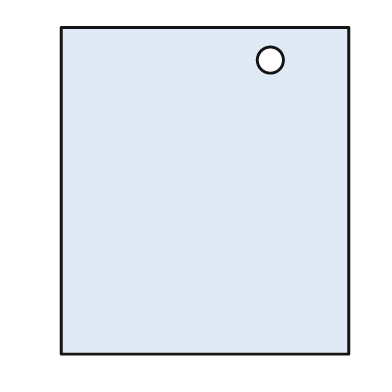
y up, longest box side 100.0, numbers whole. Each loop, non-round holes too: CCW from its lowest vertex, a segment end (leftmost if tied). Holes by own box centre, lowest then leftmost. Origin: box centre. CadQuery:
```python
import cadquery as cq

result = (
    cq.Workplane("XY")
    .moveTo(-44.0, -50.0)
    .lineTo(44.0, -50.0)
    .lineTo(44.0, 50.0)
    .lineTo(-44.0, 50.0)
    .close()
    .moveTo(20.0, 40.0)
    .circle(4.0)
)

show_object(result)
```